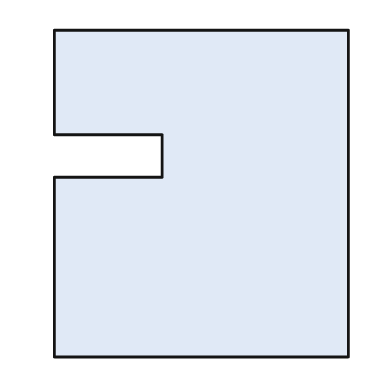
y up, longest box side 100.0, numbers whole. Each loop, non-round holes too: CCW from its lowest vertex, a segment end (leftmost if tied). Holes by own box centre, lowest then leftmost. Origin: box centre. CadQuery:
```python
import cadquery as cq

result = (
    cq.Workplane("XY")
    .moveTo(-45.0, -50.0)
    .lineTo(45.0, -50.0)
    .lineTo(45.0, 50.0)
    .lineTo(-45.0, 50.0)
    .lineTo(-45.0, 18.0)
    .lineTo(-12.0, 18.0)
    .lineTo(-12.0, 5.0)
    .lineTo(-45.0, 5.0)
    .close()
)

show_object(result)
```